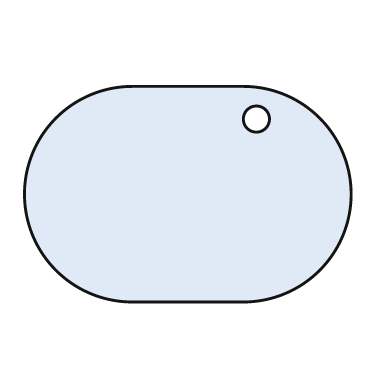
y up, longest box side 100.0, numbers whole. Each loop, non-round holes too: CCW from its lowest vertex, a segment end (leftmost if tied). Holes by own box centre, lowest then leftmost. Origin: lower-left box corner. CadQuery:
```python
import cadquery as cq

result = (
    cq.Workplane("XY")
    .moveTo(33.0, 0.0)
    .lineTo(67.0, 0.0)
    .threePointArc((100.0, 33.0), (67.0, 66.0))
    .lineTo(33.0, 66.0)
    .threePointArc((0.0, 33.0), (33.0, 0.0))
    .close()
    .moveTo(71.0, 56.0)
    .circle(4.0)
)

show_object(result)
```